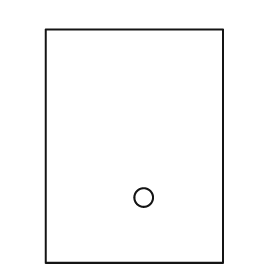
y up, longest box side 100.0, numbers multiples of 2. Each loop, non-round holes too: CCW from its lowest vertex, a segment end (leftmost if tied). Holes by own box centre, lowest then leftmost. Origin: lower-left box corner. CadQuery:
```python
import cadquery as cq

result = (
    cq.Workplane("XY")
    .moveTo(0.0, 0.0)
    .lineTo(76.0, 0.0)
    .lineTo(76.0, 100.0)
    .lineTo(0.0, 100.0)
    .close()
    .moveTo(42.0, 28.0)
    .circle(4.0)
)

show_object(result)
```